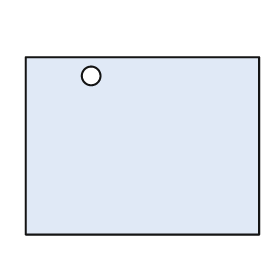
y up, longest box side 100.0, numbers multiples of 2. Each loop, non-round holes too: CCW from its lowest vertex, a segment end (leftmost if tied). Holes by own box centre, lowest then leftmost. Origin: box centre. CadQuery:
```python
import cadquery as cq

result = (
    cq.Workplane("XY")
    .moveTo(-50.0, -38.0)
    .lineTo(50.0, -38.0)
    .lineTo(50.0, 38.0)
    .lineTo(-50.0, 38.0)
    .close()
    .moveTo(-22.0, 30.0)
    .circle(4.0)
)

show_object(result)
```